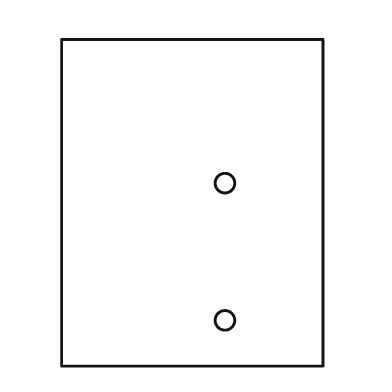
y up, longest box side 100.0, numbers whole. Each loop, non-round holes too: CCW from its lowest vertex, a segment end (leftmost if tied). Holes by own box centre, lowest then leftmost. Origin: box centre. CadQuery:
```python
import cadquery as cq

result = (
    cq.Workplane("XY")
    .moveTo(-40.0, -50.0)
    .lineTo(40.0, -50.0)
    .lineTo(40.0, 50.0)
    .lineTo(-40.0, 50.0)
    .close()
    .moveTo(10.0, -36.0)
    .circle(3.0)
    .moveTo(10.0, 6.0)
    .circle(3.0)
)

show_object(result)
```